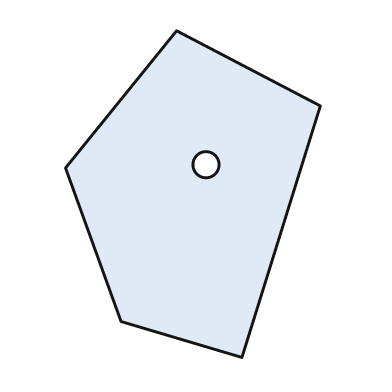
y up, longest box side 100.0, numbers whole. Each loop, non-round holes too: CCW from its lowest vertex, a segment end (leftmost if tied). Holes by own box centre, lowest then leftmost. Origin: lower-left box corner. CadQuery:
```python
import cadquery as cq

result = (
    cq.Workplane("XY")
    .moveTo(54.0, 0.0)
    .lineTo(78.0, 77.0)
    .lineTo(34.0, 100.0)
    .lineTo(0.0, 58.0)
    .lineTo(17.0, 11.0)
    .close()
    .moveTo(43.0, 59.0)
    .circle(4.0)
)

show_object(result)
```